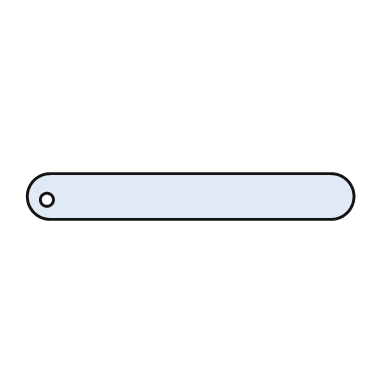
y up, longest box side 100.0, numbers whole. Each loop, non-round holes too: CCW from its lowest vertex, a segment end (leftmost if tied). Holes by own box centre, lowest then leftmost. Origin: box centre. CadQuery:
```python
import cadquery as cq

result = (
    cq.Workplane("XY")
    .moveTo(-43.0, -7.0)
    .lineTo(43.0, -7.0)
    .threePointArc((50.0, 0.0), (43.0, 7.0))
    .lineTo(-43.0, 7.0)
    .threePointArc((-50.0, 0.0), (-43.0, -7.0))
    .close()
    .moveTo(-44.0, -1.0)
    .circle(2.0)
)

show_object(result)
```